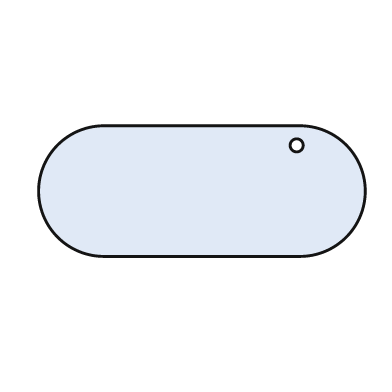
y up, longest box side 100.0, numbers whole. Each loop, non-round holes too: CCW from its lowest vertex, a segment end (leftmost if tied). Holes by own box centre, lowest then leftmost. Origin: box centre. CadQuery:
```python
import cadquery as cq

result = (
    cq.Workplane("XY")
    .moveTo(-30.0, -20.0)
    .lineTo(30.0, -20.0)
    .threePointArc((50.0, 0.0), (30.0, 20.0))
    .lineTo(-30.0, 20.0)
    .threePointArc((-50.0, 0.0), (-30.0, -20.0))
    .close()
    .moveTo(29.0, 14.0)
    .circle(2.0)
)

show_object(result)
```